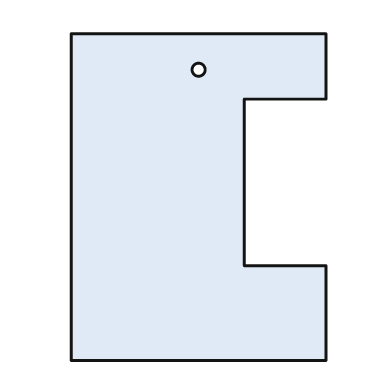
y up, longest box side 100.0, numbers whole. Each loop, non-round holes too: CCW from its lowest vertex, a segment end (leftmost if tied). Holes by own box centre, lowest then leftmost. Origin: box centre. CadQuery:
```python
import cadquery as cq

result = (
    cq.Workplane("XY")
    .moveTo(-39.0, -50.0)
    .lineTo(39.0, -50.0)
    .lineTo(39.0, -21.0)
    .lineTo(14.0, -21.0)
    .lineTo(14.0, 30.0)
    .lineTo(39.0, 30.0)
    .lineTo(39.0, 50.0)
    .lineTo(-39.0, 50.0)
    .close()
    .moveTo(0.0, 39.0)
    .circle(2.0)
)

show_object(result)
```